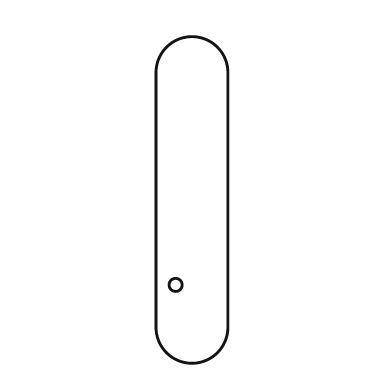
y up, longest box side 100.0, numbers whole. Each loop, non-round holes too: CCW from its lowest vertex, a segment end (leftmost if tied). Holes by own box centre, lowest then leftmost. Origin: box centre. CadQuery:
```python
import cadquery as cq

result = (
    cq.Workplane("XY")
    .moveTo(-11.0, -39.0)
    .threePointArc((0.0, -50.0), (11.0, -39.0))
    .lineTo(11.0, 39.0)
    .threePointArc((0.0, 50.0), (-11.0, 39.0))
    .close()
    .moveTo(-5.0, -26.0)
    .circle(2.0)
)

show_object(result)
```